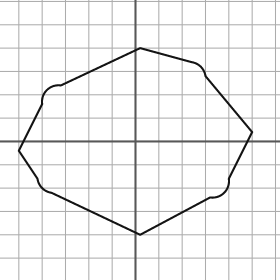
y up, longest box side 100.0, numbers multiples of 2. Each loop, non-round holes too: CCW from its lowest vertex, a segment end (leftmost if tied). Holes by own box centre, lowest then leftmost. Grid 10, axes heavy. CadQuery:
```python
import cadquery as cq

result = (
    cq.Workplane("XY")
    .moveTo(2.0, -40.0)
    .lineTo(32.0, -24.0)
    .threePointArc((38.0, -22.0), (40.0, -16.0))
    .lineTo(50.0, 4.0)
    .lineTo(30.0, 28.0)
    .threePointArc((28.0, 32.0), (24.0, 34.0))
    .lineTo(2.0, 40.0)
    .lineTo(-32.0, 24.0)
    .threePointArc((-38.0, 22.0), (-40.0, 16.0))
    .lineTo(-50.0, -4.0)
    .lineTo(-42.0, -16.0)
    .threePointArc((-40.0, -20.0), (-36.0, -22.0))
    .close()
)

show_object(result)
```